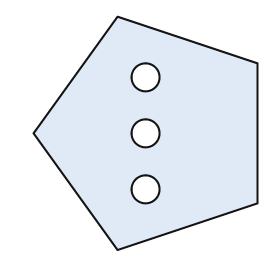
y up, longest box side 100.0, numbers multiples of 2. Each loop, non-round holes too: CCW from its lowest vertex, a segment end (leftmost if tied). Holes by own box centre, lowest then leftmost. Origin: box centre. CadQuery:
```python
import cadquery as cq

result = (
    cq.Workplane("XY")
    .moveTo(-12.0, -50.0)
    .lineTo(48.0, -30.0)
    .lineTo(48.0, 30.0)
    .lineTo(-12.0, 50.0)
    .lineTo(-48.0, 0.0)
    .close()
    .moveTo(0.0, -24.0)
    .circle(6.0)
    .moveTo(0.0, 0.0)
    .circle(6.0)
    .moveTo(0.0, 24.0)
    .circle(6.0)
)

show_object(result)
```